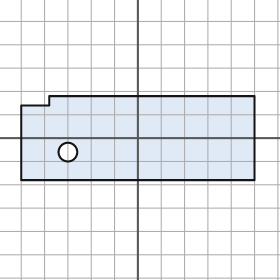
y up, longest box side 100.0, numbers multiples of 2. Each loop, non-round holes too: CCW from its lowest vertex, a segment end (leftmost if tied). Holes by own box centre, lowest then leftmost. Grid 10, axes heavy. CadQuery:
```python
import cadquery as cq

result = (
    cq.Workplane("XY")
    .moveTo(-50.0, -18.0)
    .lineTo(50.0, -18.0)
    .lineTo(50.0, 18.0)
    .lineTo(-38.0, 18.0)
    .lineTo(-38.0, 14.0)
    .lineTo(-50.0, 14.0)
    .close()
    .moveTo(-30.0, -6.0)
    .circle(4.0)
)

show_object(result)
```